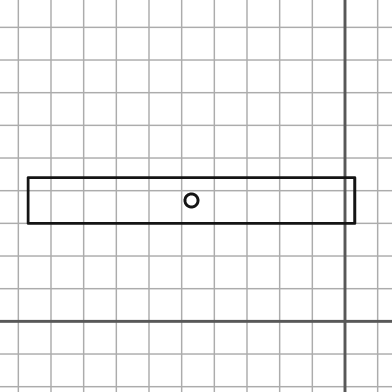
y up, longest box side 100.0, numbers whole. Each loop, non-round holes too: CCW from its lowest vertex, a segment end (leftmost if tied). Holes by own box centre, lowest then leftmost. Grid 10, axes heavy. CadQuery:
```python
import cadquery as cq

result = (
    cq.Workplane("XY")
    .moveTo(-97.0, 30.0)
    .lineTo(3.0, 30.0)
    .lineTo(3.0, 44.0)
    .lineTo(-97.0, 44.0)
    .close()
    .moveTo(-47.0, 37.0)
    .circle(2.0)
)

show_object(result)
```